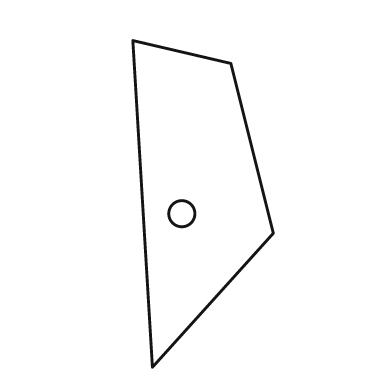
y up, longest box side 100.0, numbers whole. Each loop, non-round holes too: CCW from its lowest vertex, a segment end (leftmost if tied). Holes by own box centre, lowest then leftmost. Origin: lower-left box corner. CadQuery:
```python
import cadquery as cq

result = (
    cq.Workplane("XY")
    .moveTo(6.0, 0.0)
    .lineTo(43.0, 41.0)
    .lineTo(30.0, 93.0)
    .lineTo(0.0, 100.0)
    .close()
    .moveTo(15.0, 47.0)
    .circle(4.0)
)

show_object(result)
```